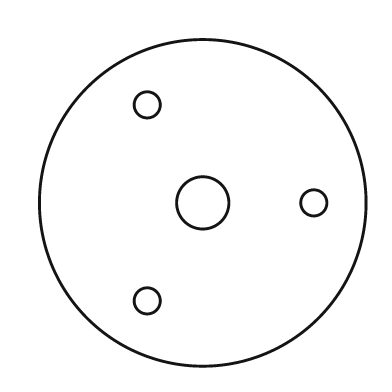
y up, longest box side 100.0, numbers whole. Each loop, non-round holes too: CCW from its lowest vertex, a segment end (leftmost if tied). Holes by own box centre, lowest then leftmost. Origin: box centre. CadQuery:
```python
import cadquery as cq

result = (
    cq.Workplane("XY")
    .moveTo(0.0, 0.0)
    .circle(50.0)
    .moveTo(-17.0, -30.0)
    .circle(4.0)
    .moveTo(0.0, 0.0)
    .circle(8.0)
    .moveTo(34.0, 0.0)
    .circle(4.0)
    .moveTo(-17.0, 30.0)
    .circle(4.0)
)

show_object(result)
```